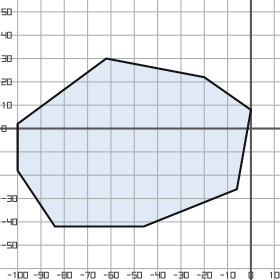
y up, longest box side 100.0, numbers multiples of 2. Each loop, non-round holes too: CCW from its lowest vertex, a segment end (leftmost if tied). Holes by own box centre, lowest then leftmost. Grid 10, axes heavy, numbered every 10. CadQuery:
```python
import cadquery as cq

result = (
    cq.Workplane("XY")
    .moveTo(-84.0, -42.0)
    .lineTo(-46.0, -42.0)
    .lineTo(-6.0, -26.0)
    .lineTo(0.0, 8.0)
    .lineTo(-20.0, 22.0)
    .lineTo(-62.0, 30.0)
    .lineTo(-100.0, 2.0)
    .lineTo(-100.0, -18.0)
    .close()
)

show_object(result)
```